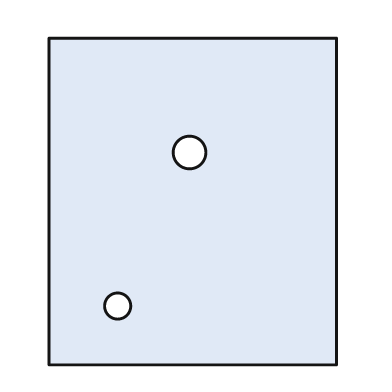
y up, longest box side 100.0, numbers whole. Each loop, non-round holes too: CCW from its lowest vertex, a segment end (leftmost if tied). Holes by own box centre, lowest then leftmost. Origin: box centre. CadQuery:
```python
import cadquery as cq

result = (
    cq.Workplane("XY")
    .moveTo(-44.0, -50.0)
    .lineTo(44.0, -50.0)
    .lineTo(44.0, 50.0)
    .lineTo(-44.0, 50.0)
    .close()
    .moveTo(-23.0, -32.0)
    .circle(4.0)
    .moveTo(-1.0, 15.0)
    .circle(5.0)
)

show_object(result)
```